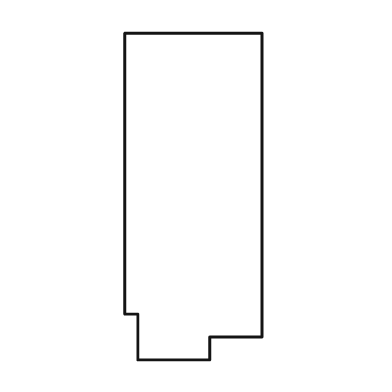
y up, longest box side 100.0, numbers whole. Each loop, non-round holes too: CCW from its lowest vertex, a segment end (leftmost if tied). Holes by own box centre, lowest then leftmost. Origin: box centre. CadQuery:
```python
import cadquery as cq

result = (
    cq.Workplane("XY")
    .moveTo(-17.0, -50.0)
    .lineTo(5.0, -50.0)
    .lineTo(5.0, -43.0)
    .lineTo(21.0, -43.0)
    .lineTo(21.0, 50.0)
    .lineTo(-21.0, 50.0)
    .lineTo(-21.0, -36.0)
    .lineTo(-17.0, -36.0)
    .close()
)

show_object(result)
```